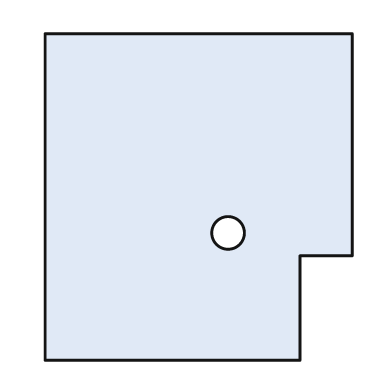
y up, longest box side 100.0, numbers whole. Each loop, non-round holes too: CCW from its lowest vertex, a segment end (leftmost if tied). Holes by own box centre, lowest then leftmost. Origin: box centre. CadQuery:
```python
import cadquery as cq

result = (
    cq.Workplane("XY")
    .moveTo(-47.0, -50.0)
    .lineTo(31.0, -50.0)
    .lineTo(31.0, -18.0)
    .lineTo(47.0, -18.0)
    .lineTo(47.0, 50.0)
    .lineTo(-47.0, 50.0)
    .close()
    .moveTo(9.0, -11.0)
    .circle(5.0)
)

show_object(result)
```